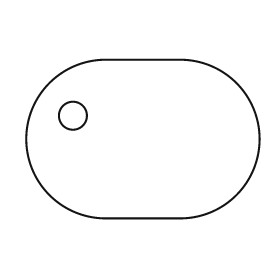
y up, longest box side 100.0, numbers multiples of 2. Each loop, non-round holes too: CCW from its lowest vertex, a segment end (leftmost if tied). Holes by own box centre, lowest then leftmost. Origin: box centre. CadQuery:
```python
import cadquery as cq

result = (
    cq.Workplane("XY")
    .moveTo(-16.0, -34.0)
    .lineTo(16.0, -34.0)
    .threePointArc((50.0, 0.0), (16.0, 34.0))
    .lineTo(-16.0, 34.0)
    .threePointArc((-50.0, 0.0), (-16.0, -34.0))
    .close()
    .moveTo(-30.0, 10.0)
    .circle(6.0)
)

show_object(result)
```